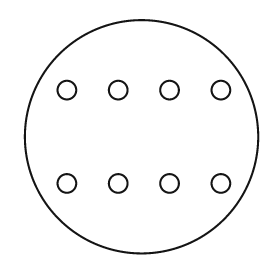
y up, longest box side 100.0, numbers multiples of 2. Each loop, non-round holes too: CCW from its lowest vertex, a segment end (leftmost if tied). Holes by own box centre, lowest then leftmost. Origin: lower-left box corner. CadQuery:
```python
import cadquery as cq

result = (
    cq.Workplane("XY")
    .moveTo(50.0, 50.0)
    .circle(50.0)
    .moveTo(18.0, 30.0)
    .circle(4.0)
    .moveTo(40.0, 30.0)
    .circle(4.0)
    .moveTo(62.0, 30.0)
    .circle(4.0)
    .moveTo(84.0, 30.0)
    .circle(4.0)
    .moveTo(18.0, 70.0)
    .circle(4.0)
    .moveTo(40.0, 70.0)
    .circle(4.0)
    .moveTo(62.0, 70.0)
    .circle(4.0)
    .moveTo(84.0, 70.0)
    .circle(4.0)
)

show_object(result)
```